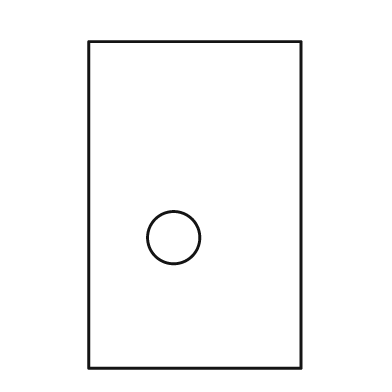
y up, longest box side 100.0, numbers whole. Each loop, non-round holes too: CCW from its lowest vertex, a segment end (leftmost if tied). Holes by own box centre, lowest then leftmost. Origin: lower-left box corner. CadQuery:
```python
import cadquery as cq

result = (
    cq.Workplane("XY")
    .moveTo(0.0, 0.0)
    .lineTo(65.0, 0.0)
    .lineTo(65.0, 100.0)
    .lineTo(0.0, 100.0)
    .close()
    .moveTo(26.0, 40.0)
    .circle(8.0)
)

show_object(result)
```